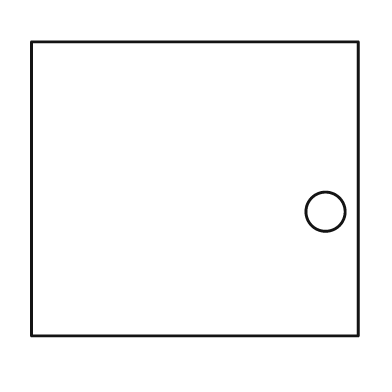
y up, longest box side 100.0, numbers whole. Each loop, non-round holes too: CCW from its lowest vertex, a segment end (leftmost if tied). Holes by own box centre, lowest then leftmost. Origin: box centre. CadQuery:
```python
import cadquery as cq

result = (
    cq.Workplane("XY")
    .moveTo(-50.0, -45.0)
    .lineTo(50.0, -45.0)
    .lineTo(50.0, 45.0)
    .lineTo(-50.0, 45.0)
    .close()
    .moveTo(40.0, -7.0)
    .circle(6.0)
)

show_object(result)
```